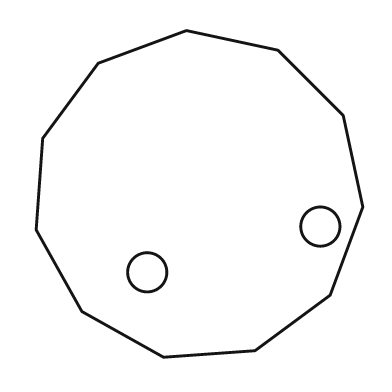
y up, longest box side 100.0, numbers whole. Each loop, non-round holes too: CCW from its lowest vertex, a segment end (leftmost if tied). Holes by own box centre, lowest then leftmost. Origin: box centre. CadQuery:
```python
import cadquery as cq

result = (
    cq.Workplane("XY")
    .moveTo(-11.0, -50.0)
    .lineTo(17.0, -48.0)
    .lineTo(40.0, -31.0)
    .lineTo(50.0, -4.0)
    .lineTo(44.0, 24.0)
    .lineTo(24.0, 44.0)
    .lineTo(-4.0, 50.0)
    .lineTo(-31.0, 40.0)
    .lineTo(-48.0, 17.0)
    .lineTo(-50.0, -11.0)
    .lineTo(-36.0, -36.0)
    .close()
    .moveTo(-16.0, -24.0)
    .circle(6.0)
    .moveTo(37.0, -10.0)
    .circle(6.0)
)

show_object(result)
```